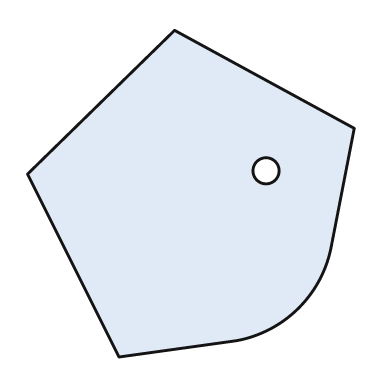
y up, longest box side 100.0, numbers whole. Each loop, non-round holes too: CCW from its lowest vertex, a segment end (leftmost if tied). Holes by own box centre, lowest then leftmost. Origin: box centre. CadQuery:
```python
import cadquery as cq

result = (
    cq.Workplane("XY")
    .moveTo(-22.0, -50.0)
    .lineTo(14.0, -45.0)
    .threePointArc((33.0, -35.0), (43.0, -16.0))
    .lineTo(50.0, 20.0)
    .lineTo(-5.0, 50.0)
    .lineTo(-50.0, 6.0)
    .close()
    .moveTo(23.0, 7.0)
    .circle(4.0)
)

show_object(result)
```